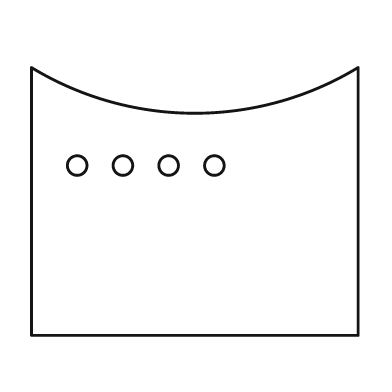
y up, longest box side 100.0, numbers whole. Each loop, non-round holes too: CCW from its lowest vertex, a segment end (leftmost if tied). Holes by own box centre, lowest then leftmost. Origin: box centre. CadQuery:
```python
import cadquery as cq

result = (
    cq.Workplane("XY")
    .moveTo(-50.0, -41.0)
    .lineTo(50.0, -41.0)
    .lineTo(50.0, 41.0)
    .threePointArc((0.0, 27.0), (-50.0, 41.0))
    .close()
    .moveTo(-36.0, 11.0)
    .circle(3.0)
    .moveTo(-22.0, 11.0)
    .circle(3.0)
    .moveTo(-8.0, 11.0)
    .circle(3.0)
    .moveTo(6.0, 11.0)
    .circle(3.0)
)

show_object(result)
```